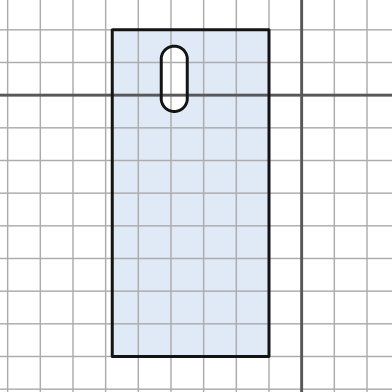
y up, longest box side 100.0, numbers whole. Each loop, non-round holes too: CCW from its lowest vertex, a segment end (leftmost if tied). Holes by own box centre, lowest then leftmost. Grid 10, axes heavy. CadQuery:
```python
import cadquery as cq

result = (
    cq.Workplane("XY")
    .moveTo(-58.0, -80.0)
    .lineTo(-10.0, -80.0)
    .lineTo(-10.0, 20.0)
    .lineTo(-58.0, 20.0)
    .close()
    .moveTo(-43.0, -1.0)
    .threePointArc((-39.0, -5.0), (-35.0, -1.0))
    .lineTo(-35.0, 11.0)
    .threePointArc((-39.0, 15.0), (-43.0, 11.0))
    .close()
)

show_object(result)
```